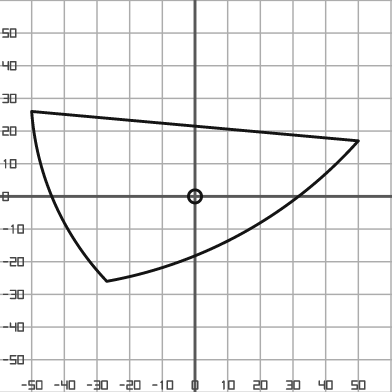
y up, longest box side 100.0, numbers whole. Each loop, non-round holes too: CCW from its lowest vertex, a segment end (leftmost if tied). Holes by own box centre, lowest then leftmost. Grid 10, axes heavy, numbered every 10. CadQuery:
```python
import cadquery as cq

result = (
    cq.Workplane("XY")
    .moveTo(-27.0, -26.0)
    .threePointArc((15.0, -11.0), (50.0, 17.0))
    .lineTo(-50.0, 26.0)
    .threePointArc((-43.0, -2.0), (-27.0, -26.0))
    .close()
    .moveTo(0.0, 0.0)
    .circle(2.0)
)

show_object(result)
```